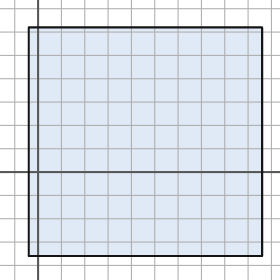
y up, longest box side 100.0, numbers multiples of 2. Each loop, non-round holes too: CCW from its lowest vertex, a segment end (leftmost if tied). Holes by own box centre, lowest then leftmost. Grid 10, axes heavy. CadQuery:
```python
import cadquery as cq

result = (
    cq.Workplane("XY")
    .moveTo(-4.0, -36.0)
    .lineTo(96.0, -36.0)
    .lineTo(96.0, 62.0)
    .lineTo(-4.0, 62.0)
    .close()
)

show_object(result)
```